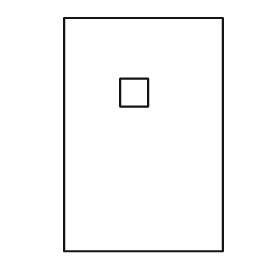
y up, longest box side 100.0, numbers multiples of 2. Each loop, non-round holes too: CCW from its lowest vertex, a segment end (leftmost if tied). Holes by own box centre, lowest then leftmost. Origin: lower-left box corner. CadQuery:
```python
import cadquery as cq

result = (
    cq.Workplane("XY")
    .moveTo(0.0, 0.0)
    .lineTo(68.0, 0.0)
    .lineTo(68.0, 100.0)
    .lineTo(0.0, 100.0)
    .close()
    .moveTo(24.0, 62.0)
    .lineTo(36.0, 62.0)
    .lineTo(36.0, 74.0)
    .lineTo(24.0, 74.0)
    .close()
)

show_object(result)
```